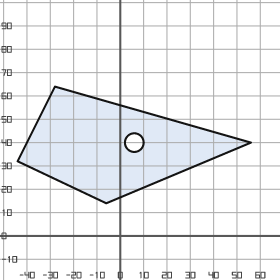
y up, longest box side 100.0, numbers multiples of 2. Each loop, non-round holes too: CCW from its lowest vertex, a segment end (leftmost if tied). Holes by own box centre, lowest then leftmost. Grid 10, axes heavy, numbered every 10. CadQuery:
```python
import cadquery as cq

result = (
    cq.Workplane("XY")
    .moveTo(-6.0, 14.0)
    .lineTo(56.0, 40.0)
    .lineTo(-28.0, 64.0)
    .lineTo(-44.0, 32.0)
    .close()
    .moveTo(6.0, 40.0)
    .circle(4.0)
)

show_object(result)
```